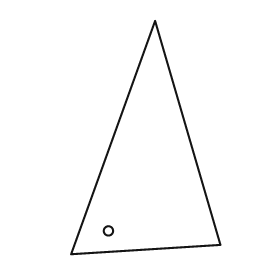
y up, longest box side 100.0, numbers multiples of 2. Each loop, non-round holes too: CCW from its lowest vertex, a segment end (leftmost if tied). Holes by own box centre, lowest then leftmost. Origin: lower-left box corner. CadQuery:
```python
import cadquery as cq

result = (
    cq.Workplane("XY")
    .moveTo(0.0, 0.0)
    .lineTo(64.0, 4.0)
    .lineTo(36.0, 100.0)
    .close()
    .moveTo(16.0, 10.0)
    .circle(2.0)
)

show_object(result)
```